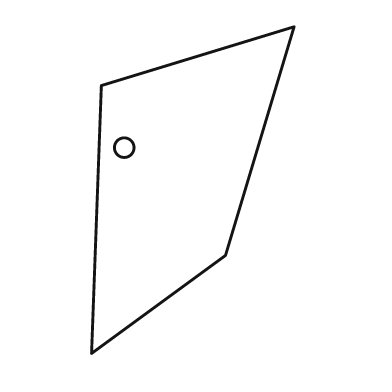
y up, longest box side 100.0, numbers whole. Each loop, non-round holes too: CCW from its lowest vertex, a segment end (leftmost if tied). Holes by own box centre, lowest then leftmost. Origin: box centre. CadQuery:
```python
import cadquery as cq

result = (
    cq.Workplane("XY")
    .moveTo(-31.0, -50.0)
    .lineTo(10.0, -20.0)
    .lineTo(31.0, 50.0)
    .lineTo(-28.0, 32.0)
    .close()
    .moveTo(-21.0, 13.0)
    .circle(3.0)
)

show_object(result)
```